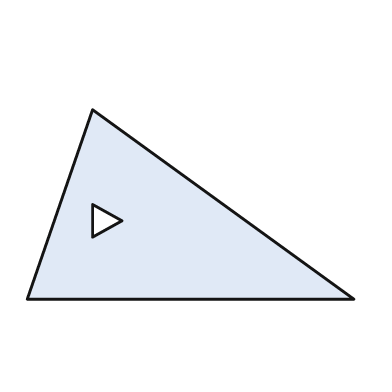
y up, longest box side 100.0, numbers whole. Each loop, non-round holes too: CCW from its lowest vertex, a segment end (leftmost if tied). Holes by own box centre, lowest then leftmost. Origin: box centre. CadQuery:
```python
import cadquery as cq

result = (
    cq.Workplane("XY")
    .moveTo(-50.0, -29.0)
    .lineTo(50.0, -29.0)
    .lineTo(-30.0, 29.0)
    .close()
    .moveTo(-30.0, -10.0)
    .lineTo(-21.0, -5.0)
    .lineTo(-30.0, 0.0)
    .close()
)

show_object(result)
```